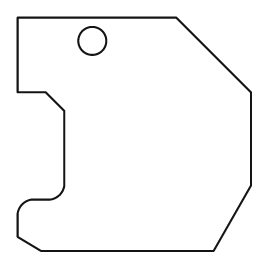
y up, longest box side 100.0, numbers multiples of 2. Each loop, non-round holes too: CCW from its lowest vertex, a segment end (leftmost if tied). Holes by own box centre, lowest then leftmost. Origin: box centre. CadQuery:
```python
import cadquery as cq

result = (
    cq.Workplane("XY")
    .moveTo(-40.0, -50.0)
    .lineTo(34.0, -50.0)
    .lineTo(50.0, -22.0)
    .lineTo(50.0, 18.0)
    .lineTo(18.0, 50.0)
    .lineTo(-50.0, 50.0)
    .lineTo(-50.0, 18.0)
    .lineTo(-38.0, 18.0)
    .lineTo(-30.0, 10.0)
    .lineTo(-30.0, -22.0)
    .threePointArc((-32.0, -26.0), (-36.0, -28.0))
    .lineTo(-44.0, -28.0)
    .threePointArc((-48.0, -30.0), (-50.0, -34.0))
    .lineTo(-50.0, -44.0)
    .close()
    .moveTo(-18.0, 40.0)
    .circle(6.0)
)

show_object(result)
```